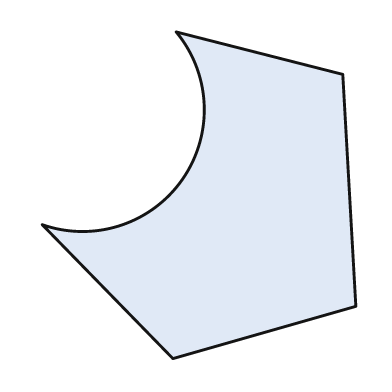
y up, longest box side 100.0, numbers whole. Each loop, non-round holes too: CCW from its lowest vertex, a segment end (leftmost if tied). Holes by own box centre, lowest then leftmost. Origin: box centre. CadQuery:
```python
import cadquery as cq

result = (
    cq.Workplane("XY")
    .moveTo(-8.0, -50.0)
    .lineTo(48.0, -34.0)
    .lineTo(44.0, 37.0)
    .lineTo(-7.0, 50.0)
    .threePointArc((-5.0, 5.0), (-48.0, -9.0))
    .close()
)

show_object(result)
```